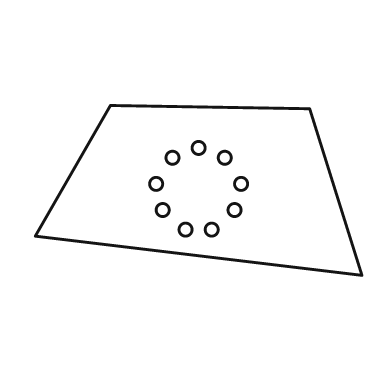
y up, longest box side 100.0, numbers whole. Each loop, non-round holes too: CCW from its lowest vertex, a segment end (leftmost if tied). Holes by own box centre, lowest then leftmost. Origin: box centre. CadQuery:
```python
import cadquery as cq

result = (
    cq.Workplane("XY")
    .moveTo(50.0, -26.0)
    .lineTo(34.0, 25.0)
    .lineTo(-27.0, 26.0)
    .lineTo(-50.0, -14.0)
    .close()
    .moveTo(-4.0, -12.0)
    .circle(2.0)
    .moveTo(4.0, -12.0)
    .circle(2.0)
    .moveTo(-11.0, -6.0)
    .circle(2.0)
    .moveTo(11.0, -6.0)
    .circle(2.0)
    .moveTo(-13.0, 2.0)
    .circle(2.0)
    .moveTo(13.0, 2.0)
    .circle(2.0)
    .moveTo(-8.0, 10.0)
    .circle(2.0)
    .moveTo(8.0, 10.0)
    .circle(2.0)
    .moveTo(0.0, 13.0)
    .circle(2.0)
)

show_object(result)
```